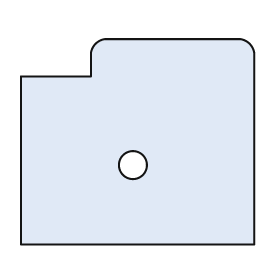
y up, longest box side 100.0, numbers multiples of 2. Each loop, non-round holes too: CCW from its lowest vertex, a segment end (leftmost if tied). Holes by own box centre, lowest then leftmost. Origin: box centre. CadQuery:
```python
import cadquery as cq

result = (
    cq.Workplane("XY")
    .moveTo(-50.0, -44.0)
    .lineTo(50.0, -44.0)
    .lineTo(50.0, 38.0)
    .threePointArc((48.0, 42.0), (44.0, 44.0))
    .lineTo(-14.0, 44.0)
    .threePointArc((-18.0, 42.0), (-20.0, 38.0))
    .lineTo(-20.0, 28.0)
    .lineTo(-50.0, 28.0)
    .close()
    .moveTo(-2.0, -10.0)
    .circle(6.0)
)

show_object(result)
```